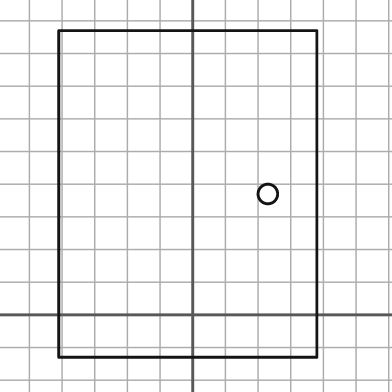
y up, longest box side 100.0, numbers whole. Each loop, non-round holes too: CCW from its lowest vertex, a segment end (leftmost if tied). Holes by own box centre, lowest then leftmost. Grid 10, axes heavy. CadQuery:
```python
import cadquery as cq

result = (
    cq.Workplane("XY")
    .moveTo(-41.0, -13.0)
    .lineTo(38.0, -13.0)
    .lineTo(38.0, 87.0)
    .lineTo(-41.0, 87.0)
    .close()
    .moveTo(23.0, 37.0)
    .circle(3.0)
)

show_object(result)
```